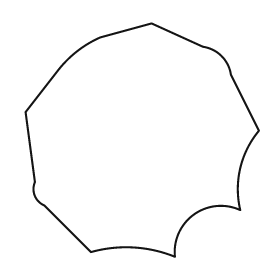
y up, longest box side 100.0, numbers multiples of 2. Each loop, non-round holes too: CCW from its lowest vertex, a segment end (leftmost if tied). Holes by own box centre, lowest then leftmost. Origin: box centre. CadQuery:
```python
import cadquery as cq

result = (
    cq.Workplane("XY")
    .moveTo(14.0, -50.0)
    .threePointArc((22.0, -32.0), (42.0, -30.0))
    .threePointArc((42.0, -12.0), (50.0, 4.0))
    .lineTo(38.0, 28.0)
    .threePointArc((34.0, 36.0), (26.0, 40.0))
    .lineTo(4.0, 50.0)
    .lineTo(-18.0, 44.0)
    .threePointArc((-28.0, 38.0), (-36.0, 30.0))
    .lineTo(-50.0, 12.0)
    .lineTo(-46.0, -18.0)
    .threePointArc((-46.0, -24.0), (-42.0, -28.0))
    .lineTo(-22.0, -48.0)
    .threePointArc((-4.0, -46.0), (14.0, -50.0))
    .close()
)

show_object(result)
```